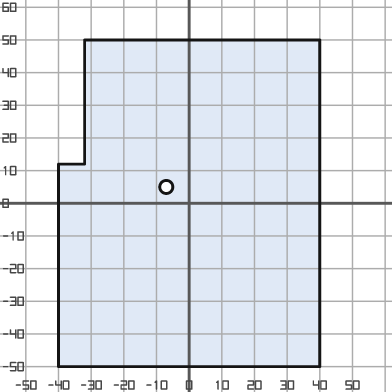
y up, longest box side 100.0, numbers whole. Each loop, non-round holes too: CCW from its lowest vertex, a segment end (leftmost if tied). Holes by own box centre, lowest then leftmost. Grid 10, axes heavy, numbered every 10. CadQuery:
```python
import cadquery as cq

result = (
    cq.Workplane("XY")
    .moveTo(-40.0, -50.0)
    .lineTo(40.0, -50.0)
    .lineTo(40.0, 50.0)
    .lineTo(-32.0, 50.0)
    .lineTo(-32.0, 12.0)
    .lineTo(-40.0, 12.0)
    .close()
    .moveTo(-7.0, 5.0)
    .circle(2.0)
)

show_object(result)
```